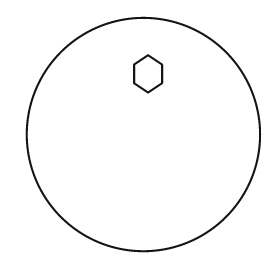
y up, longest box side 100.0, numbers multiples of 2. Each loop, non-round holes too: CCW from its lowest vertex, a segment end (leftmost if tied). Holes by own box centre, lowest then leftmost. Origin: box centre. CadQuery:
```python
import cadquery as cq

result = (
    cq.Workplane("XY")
    .moveTo(0.0, 0.0)
    .circle(50.0)
    .moveTo(2.0, 18.0)
    .lineTo(8.0, 22.0)
    .lineTo(8.0, 30.0)
    .lineTo(2.0, 34.0)
    .lineTo(-4.0, 30.0)
    .lineTo(-4.0, 22.0)
    .close()
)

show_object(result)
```